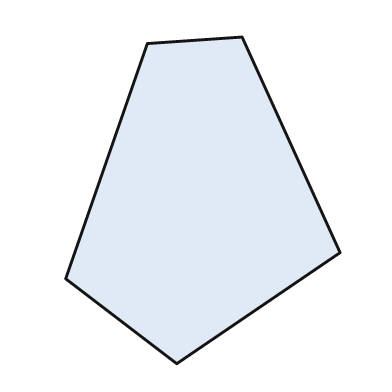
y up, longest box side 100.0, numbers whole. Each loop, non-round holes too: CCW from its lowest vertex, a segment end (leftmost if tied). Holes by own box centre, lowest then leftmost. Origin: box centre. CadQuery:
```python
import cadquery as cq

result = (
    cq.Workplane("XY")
    .moveTo(-8.0, -50.0)
    .lineTo(42.0, -16.0)
    .lineTo(12.0, 50.0)
    .lineTo(-17.0, 48.0)
    .lineTo(-42.0, -24.0)
    .close()
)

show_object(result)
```